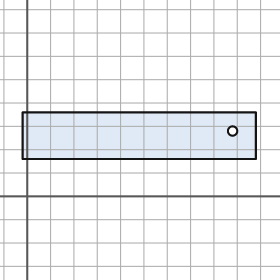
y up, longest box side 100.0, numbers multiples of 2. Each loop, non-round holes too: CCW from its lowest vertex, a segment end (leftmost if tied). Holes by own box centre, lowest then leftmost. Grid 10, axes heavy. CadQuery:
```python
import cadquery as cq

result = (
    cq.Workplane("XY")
    .moveTo(-2.0, 16.0)
    .lineTo(98.0, 16.0)
    .lineTo(98.0, 36.0)
    .lineTo(-2.0, 36.0)
    .close()
    .moveTo(88.0, 28.0)
    .circle(2.0)
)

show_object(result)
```